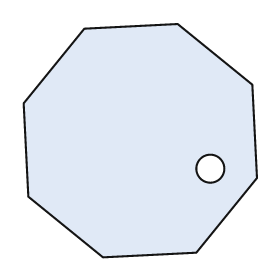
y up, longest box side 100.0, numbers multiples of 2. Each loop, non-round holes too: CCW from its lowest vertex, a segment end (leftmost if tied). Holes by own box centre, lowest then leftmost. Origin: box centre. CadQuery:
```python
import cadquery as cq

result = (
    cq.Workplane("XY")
    .moveTo(-16.0, -50.0)
    .lineTo(24.0, -48.0)
    .lineTo(50.0, -16.0)
    .lineTo(48.0, 24.0)
    .lineTo(16.0, 50.0)
    .lineTo(-24.0, 48.0)
    .lineTo(-50.0, 16.0)
    .lineTo(-48.0, -24.0)
    .close()
    .moveTo(30.0, -12.0)
    .circle(6.0)
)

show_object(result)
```